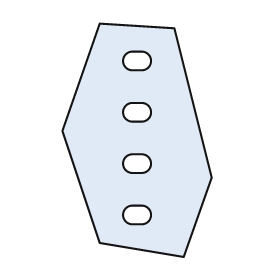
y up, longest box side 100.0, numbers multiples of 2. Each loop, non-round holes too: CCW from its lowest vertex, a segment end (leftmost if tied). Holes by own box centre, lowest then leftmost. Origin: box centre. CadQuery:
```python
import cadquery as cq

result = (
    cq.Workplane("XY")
    .moveTo(20.0, -50.0)
    .lineTo(32.0, -16.0)
    .lineTo(16.0, 48.0)
    .lineTo(-16.0, 50.0)
    .lineTo(-32.0, 4.0)
    .lineTo(-16.0, -44.0)
    .close()
    .moveTo(-2.0, -36.0)
    .lineTo(2.0, -36.0)
    .threePointArc((6.0, -32.0), (2.0, -28.0))
    .lineTo(-2.0, -28.0)
    .threePointArc((-6.0, -32.0), (-2.0, -36.0))
    .close()
    .moveTo(-2.0, -14.0)
    .lineTo(2.0, -14.0)
    .threePointArc((6.0, -10.0), (2.0, -6.0))
    .lineTo(-2.0, -6.0)
    .threePointArc((-6.0, -10.0), (-2.0, -14.0))
    .close()
    .moveTo(-2.0, 8.0)
    .lineTo(2.0, 8.0)
    .threePointArc((6.0, 12.0), (2.0, 16.0))
    .lineTo(-2.0, 16.0)
    .threePointArc((-6.0, 12.0), (-2.0, 8.0))
    .close()
    .moveTo(-2.0, 30.0)
    .lineTo(2.0, 30.0)
    .threePointArc((6.0, 34.0), (2.0, 38.0))
    .lineTo(-2.0, 38.0)
    .threePointArc((-6.0, 34.0), (-2.0, 30.0))
    .close()
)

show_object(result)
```